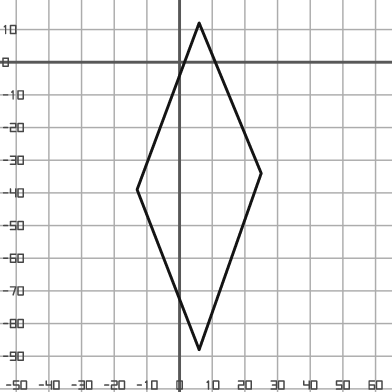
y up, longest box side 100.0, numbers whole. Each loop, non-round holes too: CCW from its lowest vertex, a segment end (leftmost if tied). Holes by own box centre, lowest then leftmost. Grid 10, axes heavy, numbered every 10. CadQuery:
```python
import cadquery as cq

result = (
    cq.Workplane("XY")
    .moveTo(6.0, -88.0)
    .lineTo(25.0, -34.0)
    .lineTo(6.0, 12.0)
    .lineTo(-13.0, -39.0)
    .close()
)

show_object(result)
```